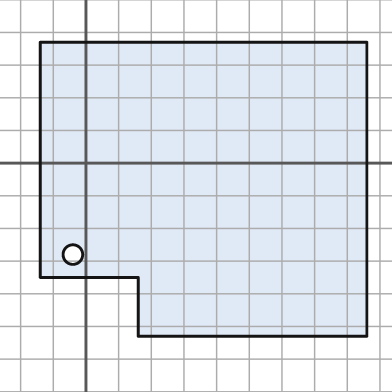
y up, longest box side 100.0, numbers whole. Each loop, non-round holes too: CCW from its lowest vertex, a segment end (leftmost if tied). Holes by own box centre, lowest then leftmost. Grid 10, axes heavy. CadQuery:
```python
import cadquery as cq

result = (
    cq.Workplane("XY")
    .moveTo(16.0, -53.0)
    .lineTo(86.0, -53.0)
    .lineTo(86.0, 37.0)
    .lineTo(-14.0, 37.0)
    .lineTo(-14.0, -35.0)
    .lineTo(16.0, -35.0)
    .close()
    .moveTo(-4.0, -28.0)
    .circle(3.0)
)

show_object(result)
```